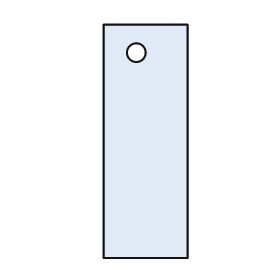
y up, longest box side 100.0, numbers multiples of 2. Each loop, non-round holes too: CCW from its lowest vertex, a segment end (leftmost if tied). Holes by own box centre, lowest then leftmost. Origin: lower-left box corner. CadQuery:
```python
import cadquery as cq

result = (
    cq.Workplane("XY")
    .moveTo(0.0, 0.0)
    .lineTo(36.0, 0.0)
    .lineTo(36.0, 100.0)
    .lineTo(0.0, 100.0)
    .close()
    .moveTo(14.0, 88.0)
    .circle(4.0)
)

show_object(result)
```